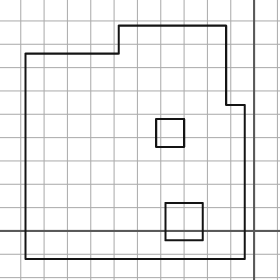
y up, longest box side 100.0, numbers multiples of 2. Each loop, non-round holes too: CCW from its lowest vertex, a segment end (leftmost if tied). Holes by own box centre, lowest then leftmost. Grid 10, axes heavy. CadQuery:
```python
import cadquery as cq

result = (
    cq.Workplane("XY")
    .moveTo(-98.0, -12.0)
    .lineTo(-4.0, -12.0)
    .lineTo(-4.0, 54.0)
    .lineTo(-12.0, 54.0)
    .lineTo(-12.0, 88.0)
    .lineTo(-58.0, 88.0)
    .lineTo(-58.0, 76.0)
    .lineTo(-98.0, 76.0)
    .close()
    .moveTo(-38.0, -4.0)
    .lineTo(-22.0, -4.0)
    .lineTo(-22.0, 12.0)
    .lineTo(-38.0, 12.0)
    .close()
    .moveTo(-42.0, 36.0)
    .lineTo(-30.0, 36.0)
    .lineTo(-30.0, 48.0)
    .lineTo(-42.0, 48.0)
    .close()
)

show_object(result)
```